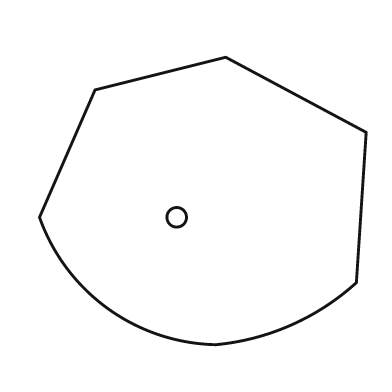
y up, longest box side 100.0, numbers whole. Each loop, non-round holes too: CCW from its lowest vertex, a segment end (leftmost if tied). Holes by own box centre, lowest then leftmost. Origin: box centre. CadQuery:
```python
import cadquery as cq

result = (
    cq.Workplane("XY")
    .moveTo(4.0, -44.0)
    .threePointArc((27.0, -38.0), (47.0, -25.0))
    .lineTo(50.0, 21.0)
    .lineTo(7.0, 44.0)
    .lineTo(-33.0, 34.0)
    .lineTo(-50.0, -5.0)
    .threePointArc((-29.0, -33.0), (4.0, -44.0))
    .close()
    .moveTo(-8.0, -5.0)
    .circle(3.0)
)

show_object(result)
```